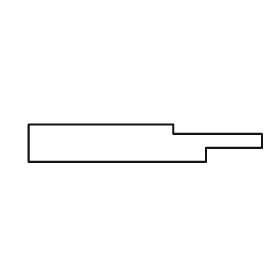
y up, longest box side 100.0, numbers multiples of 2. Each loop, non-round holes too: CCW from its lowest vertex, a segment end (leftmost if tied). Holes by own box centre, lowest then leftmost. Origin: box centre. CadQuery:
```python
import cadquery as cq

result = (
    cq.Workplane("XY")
    .moveTo(-50.0, -8.0)
    .lineTo(26.0, -8.0)
    .lineTo(26.0, -2.0)
    .lineTo(50.0, -2.0)
    .lineTo(50.0, 4.0)
    .lineTo(12.0, 4.0)
    .lineTo(12.0, 8.0)
    .lineTo(-50.0, 8.0)
    .close()
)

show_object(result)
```